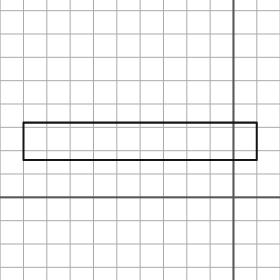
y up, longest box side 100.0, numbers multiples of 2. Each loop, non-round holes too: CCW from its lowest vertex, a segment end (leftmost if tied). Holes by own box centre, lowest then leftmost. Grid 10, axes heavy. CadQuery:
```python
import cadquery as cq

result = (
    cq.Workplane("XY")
    .moveTo(-90.0, 16.0)
    .lineTo(10.0, 16.0)
    .lineTo(10.0, 32.0)
    .lineTo(-90.0, 32.0)
    .close()
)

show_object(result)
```